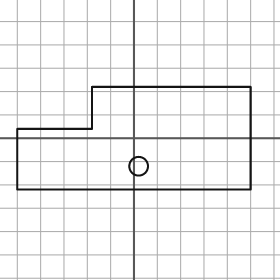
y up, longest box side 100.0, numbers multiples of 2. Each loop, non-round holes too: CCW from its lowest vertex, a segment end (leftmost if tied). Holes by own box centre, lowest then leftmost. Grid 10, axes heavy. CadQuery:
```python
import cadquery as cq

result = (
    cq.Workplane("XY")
    .moveTo(-50.0, -22.0)
    .lineTo(50.0, -22.0)
    .lineTo(50.0, 22.0)
    .lineTo(-18.0, 22.0)
    .lineTo(-18.0, 4.0)
    .lineTo(-50.0, 4.0)
    .close()
    .moveTo(2.0, -12.0)
    .circle(4.0)
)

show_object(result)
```